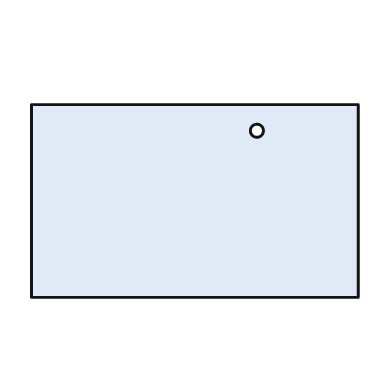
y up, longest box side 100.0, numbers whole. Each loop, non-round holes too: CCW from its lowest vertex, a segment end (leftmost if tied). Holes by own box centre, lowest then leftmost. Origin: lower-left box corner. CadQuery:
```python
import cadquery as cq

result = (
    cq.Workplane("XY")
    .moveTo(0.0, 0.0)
    .lineTo(100.0, 0.0)
    .lineTo(100.0, 59.0)
    .lineTo(0.0, 59.0)
    .close()
    .moveTo(69.0, 51.0)
    .circle(2.0)
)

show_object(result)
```